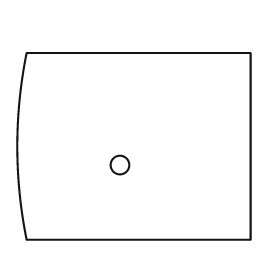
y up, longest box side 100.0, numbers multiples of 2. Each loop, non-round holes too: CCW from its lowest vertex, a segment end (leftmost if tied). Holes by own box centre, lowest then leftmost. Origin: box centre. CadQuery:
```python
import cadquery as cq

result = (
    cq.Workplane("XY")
    .moveTo(-46.0, -40.0)
    .lineTo(50.0, -40.0)
    .lineTo(50.0, 40.0)
    .lineTo(-46.0, 40.0)
    .threePointArc((-50.0, 0.0), (-46.0, -40.0))
    .close()
    .moveTo(-6.0, -8.0)
    .circle(4.0)
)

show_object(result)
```